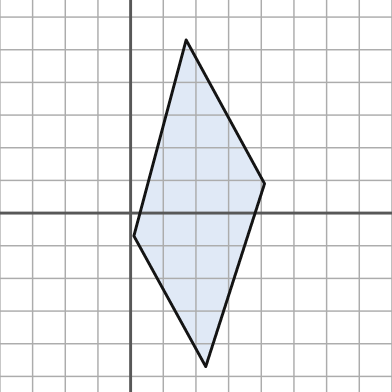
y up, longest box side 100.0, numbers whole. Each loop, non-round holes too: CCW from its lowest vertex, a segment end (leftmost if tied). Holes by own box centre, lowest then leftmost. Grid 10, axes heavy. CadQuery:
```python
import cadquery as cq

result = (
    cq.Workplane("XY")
    .moveTo(23.0, -47.0)
    .lineTo(41.0, 9.0)
    .lineTo(17.0, 53.0)
    .lineTo(1.0, -7.0)
    .close()
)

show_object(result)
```